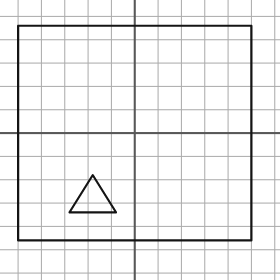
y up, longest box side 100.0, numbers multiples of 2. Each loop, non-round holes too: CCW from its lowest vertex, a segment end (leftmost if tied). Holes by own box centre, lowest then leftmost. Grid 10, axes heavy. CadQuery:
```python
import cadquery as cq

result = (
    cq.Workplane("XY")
    .moveTo(-50.0, -46.0)
    .lineTo(50.0, -46.0)
    .lineTo(50.0, 46.0)
    .lineTo(-50.0, 46.0)
    .close()
    .moveTo(-28.0, -34.0)
    .lineTo(-8.0, -34.0)
    .lineTo(-18.0, -18.0)
    .close()
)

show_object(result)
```